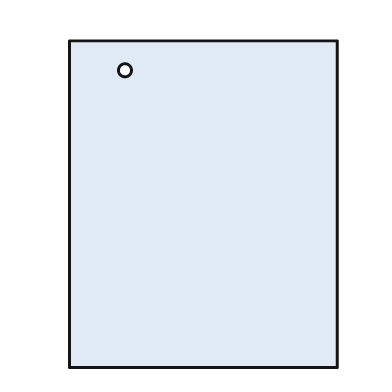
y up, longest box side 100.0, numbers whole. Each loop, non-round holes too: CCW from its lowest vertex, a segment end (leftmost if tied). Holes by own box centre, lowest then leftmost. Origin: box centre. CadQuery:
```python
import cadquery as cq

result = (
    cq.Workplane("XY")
    .moveTo(-41.0, -50.0)
    .lineTo(41.0, -50.0)
    .lineTo(41.0, 50.0)
    .lineTo(-41.0, 50.0)
    .close()
    .moveTo(-24.0, 41.0)
    .circle(2.0)
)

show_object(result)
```